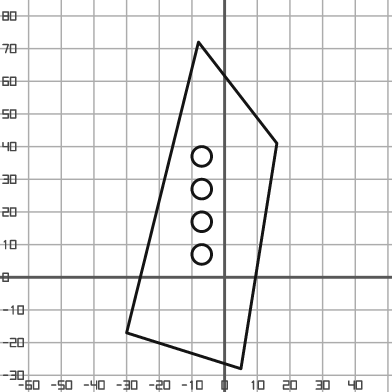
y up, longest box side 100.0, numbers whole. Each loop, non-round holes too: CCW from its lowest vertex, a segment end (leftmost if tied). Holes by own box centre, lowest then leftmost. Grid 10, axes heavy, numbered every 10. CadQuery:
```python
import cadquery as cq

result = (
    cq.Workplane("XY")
    .moveTo(5.0, -28.0)
    .lineTo(16.0, 41.0)
    .lineTo(-8.0, 72.0)
    .lineTo(-30.0, -17.0)
    .close()
    .moveTo(-7.0, 7.0)
    .circle(3.0)
    .moveTo(-7.0, 17.0)
    .circle(3.0)
    .moveTo(-7.0, 27.0)
    .circle(3.0)
    .moveTo(-7.0, 37.0)
    .circle(3.0)
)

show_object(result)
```